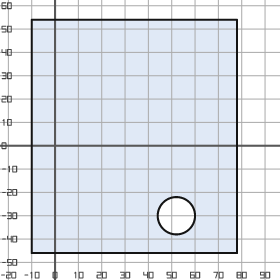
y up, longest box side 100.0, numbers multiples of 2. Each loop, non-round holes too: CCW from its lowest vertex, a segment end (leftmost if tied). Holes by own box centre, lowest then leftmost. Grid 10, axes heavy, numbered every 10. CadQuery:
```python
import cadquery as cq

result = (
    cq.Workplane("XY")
    .moveTo(-10.0, -46.0)
    .lineTo(78.0, -46.0)
    .lineTo(78.0, 54.0)
    .lineTo(-10.0, 54.0)
    .close()
    .moveTo(52.0, -30.0)
    .circle(8.0)
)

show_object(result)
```